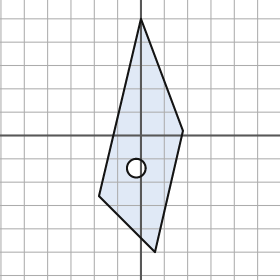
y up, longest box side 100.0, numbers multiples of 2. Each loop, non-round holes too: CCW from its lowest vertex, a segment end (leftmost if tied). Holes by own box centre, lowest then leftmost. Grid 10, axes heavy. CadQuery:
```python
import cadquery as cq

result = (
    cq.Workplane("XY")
    .moveTo(6.0, -50.0)
    .lineTo(18.0, 2.0)
    .lineTo(0.0, 50.0)
    .lineTo(-18.0, -26.0)
    .close()
    .moveTo(-2.0, -14.0)
    .circle(4.0)
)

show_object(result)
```